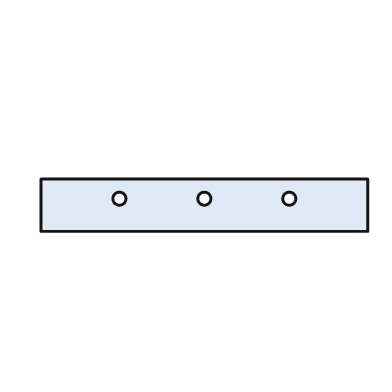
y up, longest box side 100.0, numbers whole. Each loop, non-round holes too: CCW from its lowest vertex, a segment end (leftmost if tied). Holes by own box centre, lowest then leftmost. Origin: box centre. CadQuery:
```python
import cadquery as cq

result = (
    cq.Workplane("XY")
    .moveTo(-50.0, -8.0)
    .lineTo(50.0, -8.0)
    .lineTo(50.0, 8.0)
    .lineTo(-50.0, 8.0)
    .close()
    .moveTo(-26.0, 2.0)
    .circle(2.0)
    .moveTo(0.0, 2.0)
    .circle(2.0)
    .moveTo(26.0, 2.0)
    .circle(2.0)
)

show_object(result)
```